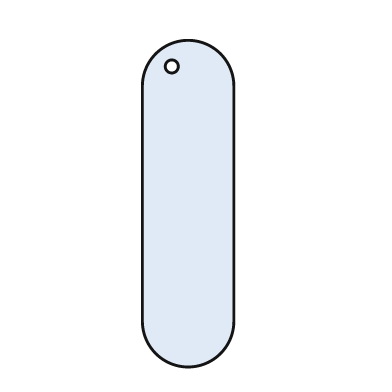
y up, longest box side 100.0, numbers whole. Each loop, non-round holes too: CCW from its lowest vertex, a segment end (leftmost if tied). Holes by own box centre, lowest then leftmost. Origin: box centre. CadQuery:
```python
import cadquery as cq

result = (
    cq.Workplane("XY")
    .moveTo(-14.0, -36.0)
    .threePointArc((0.0, -50.0), (14.0, -36.0))
    .lineTo(14.0, 36.0)
    .threePointArc((0.0, 50.0), (-14.0, 36.0))
    .close()
    .moveTo(-5.0, 42.0)
    .circle(2.0)
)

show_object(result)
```